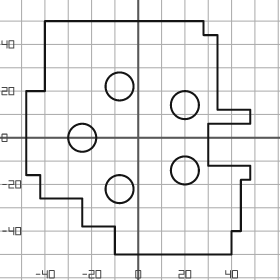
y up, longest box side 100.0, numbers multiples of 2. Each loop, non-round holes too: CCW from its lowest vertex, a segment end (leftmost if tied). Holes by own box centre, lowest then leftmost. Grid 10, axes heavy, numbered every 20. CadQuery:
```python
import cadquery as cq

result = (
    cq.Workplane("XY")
    .moveTo(-10.0, -50.0)
    .lineTo(40.0, -50.0)
    .lineTo(40.0, -40.0)
    .lineTo(44.0, -40.0)
    .lineTo(44.0, -18.0)
    .lineTo(48.0, -18.0)
    .lineTo(48.0, -12.0)
    .lineTo(30.0, -12.0)
    .lineTo(30.0, 6.0)
    .lineTo(48.0, 6.0)
    .lineTo(48.0, 12.0)
    .lineTo(34.0, 12.0)
    .lineTo(34.0, 44.0)
    .lineTo(28.0, 44.0)
    .lineTo(28.0, 50.0)
    .lineTo(-40.0, 50.0)
    .lineTo(-40.0, 20.0)
    .lineTo(-48.0, 20.0)
    .lineTo(-48.0, -16.0)
    .lineTo(-42.0, -16.0)
    .lineTo(-42.0, -26.0)
    .lineTo(-24.0, -26.0)
    .lineTo(-24.0, -38.0)
    .lineTo(-10.0, -38.0)
    .close()
    .moveTo(-8.0, -22.0)
    .circle(6.0)
    .moveTo(20.0, -14.0)
    .circle(6.0)
    .moveTo(-24.0, 0.0)
    .circle(6.0)
    .moveTo(20.0, 14.0)
    .circle(6.0)
    .moveTo(-8.0, 22.0)
    .circle(6.0)
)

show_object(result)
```